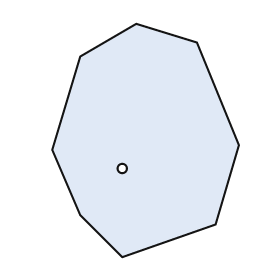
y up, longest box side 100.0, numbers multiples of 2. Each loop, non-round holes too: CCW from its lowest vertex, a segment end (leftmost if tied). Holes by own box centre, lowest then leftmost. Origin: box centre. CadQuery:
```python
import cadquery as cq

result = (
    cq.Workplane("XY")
    .moveTo(-10.0, -50.0)
    .lineTo(30.0, -36.0)
    .lineTo(40.0, -2.0)
    .lineTo(22.0, 42.0)
    .lineTo(-4.0, 50.0)
    .lineTo(-28.0, 36.0)
    .lineTo(-40.0, -4.0)
    .lineTo(-28.0, -32.0)
    .close()
    .moveTo(-10.0, -12.0)
    .circle(2.0)
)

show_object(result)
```